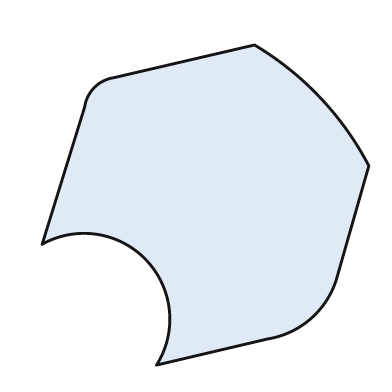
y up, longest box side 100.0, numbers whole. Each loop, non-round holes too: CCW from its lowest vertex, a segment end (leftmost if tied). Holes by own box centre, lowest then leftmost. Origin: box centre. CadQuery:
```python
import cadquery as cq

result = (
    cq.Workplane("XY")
    .moveTo(-15.0, -49.0)
    .lineTo(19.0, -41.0)
    .threePointArc((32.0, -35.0), (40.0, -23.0))
    .lineTo(50.0, 12.0)
    .threePointArc((35.0, 33.0), (15.0, 49.0))
    .lineTo(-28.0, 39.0)
    .threePointArc((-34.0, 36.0), (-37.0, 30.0))
    .lineTo(-50.0, -12.0)
    .threePointArc((-18.0, -17.0), (-15.0, -49.0))
    .close()
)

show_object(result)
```